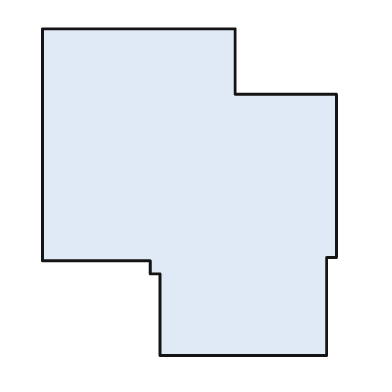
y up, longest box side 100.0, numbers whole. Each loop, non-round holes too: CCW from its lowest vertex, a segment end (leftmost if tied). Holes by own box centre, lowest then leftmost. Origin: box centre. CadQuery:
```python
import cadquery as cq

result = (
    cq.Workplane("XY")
    .moveTo(-9.0, -50.0)
    .lineTo(42.0, -50.0)
    .lineTo(42.0, -20.0)
    .lineTo(45.0, -20.0)
    .lineTo(45.0, 30.0)
    .lineTo(14.0, 30.0)
    .lineTo(14.0, 50.0)
    .lineTo(-45.0, 50.0)
    .lineTo(-45.0, -21.0)
    .lineTo(-12.0, -21.0)
    .lineTo(-12.0, -25.0)
    .lineTo(-9.0, -25.0)
    .close()
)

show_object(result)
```